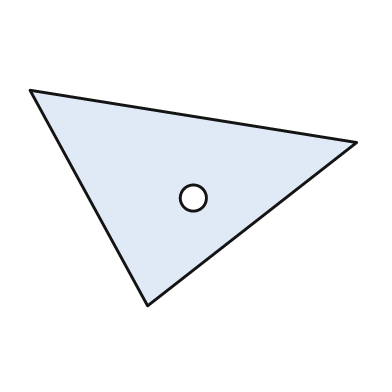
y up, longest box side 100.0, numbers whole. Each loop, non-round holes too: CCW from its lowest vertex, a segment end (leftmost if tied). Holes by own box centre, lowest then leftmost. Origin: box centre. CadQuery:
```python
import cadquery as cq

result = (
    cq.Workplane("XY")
    .moveTo(-14.0, -33.0)
    .lineTo(50.0, 17.0)
    .lineTo(-50.0, 33.0)
    .close()
    .moveTo(0.0, 0.0)
    .circle(4.0)
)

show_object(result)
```